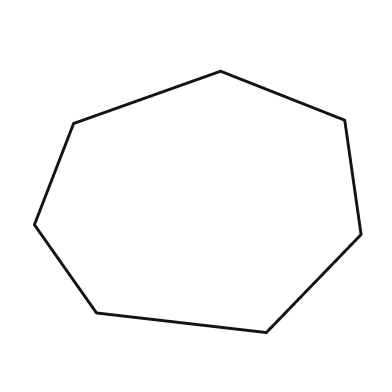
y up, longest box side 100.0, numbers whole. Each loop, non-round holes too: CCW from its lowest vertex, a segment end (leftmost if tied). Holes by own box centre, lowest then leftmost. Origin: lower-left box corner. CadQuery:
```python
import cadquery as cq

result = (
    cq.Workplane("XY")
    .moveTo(71.0, 0.0)
    .lineTo(100.0, 30.0)
    .lineTo(95.0, 65.0)
    .lineTo(57.0, 80.0)
    .lineTo(12.0, 64.0)
    .lineTo(0.0, 33.0)
    .lineTo(19.0, 6.0)
    .close()
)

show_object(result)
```